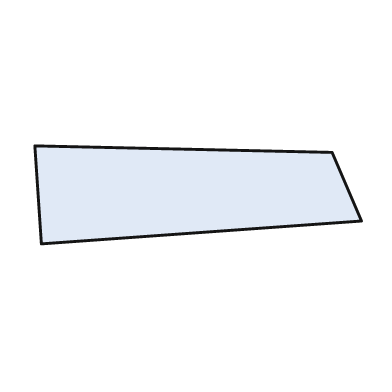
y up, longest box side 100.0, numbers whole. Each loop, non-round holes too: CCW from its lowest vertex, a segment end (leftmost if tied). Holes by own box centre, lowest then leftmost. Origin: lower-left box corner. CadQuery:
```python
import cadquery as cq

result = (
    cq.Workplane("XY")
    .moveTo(2.0, 0.0)
    .lineTo(100.0, 7.0)
    .lineTo(91.0, 28.0)
    .lineTo(0.0, 30.0)
    .close()
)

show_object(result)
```